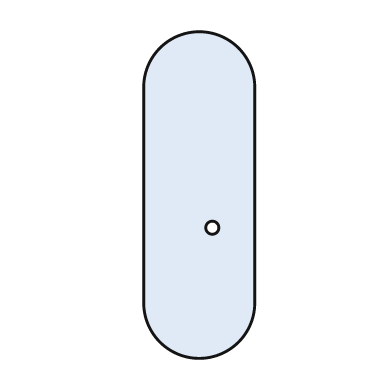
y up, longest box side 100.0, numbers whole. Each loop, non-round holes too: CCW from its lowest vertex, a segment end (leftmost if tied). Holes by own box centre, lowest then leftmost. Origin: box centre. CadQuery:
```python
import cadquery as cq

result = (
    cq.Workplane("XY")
    .moveTo(-17.0, -33.0)
    .threePointArc((0.0, -50.0), (17.0, -33.0))
    .lineTo(17.0, 33.0)
    .threePointArc((0.0, 50.0), (-17.0, 33.0))
    .close()
    .moveTo(4.0, -10.0)
    .circle(2.0)
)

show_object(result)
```